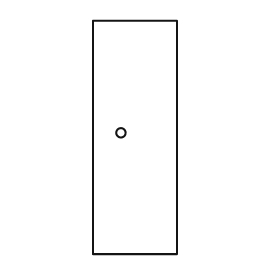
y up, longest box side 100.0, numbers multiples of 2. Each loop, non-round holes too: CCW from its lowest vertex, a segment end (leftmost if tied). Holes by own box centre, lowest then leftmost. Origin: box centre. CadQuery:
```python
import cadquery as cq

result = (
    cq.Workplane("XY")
    .moveTo(-18.0, -50.0)
    .lineTo(18.0, -50.0)
    .lineTo(18.0, 50.0)
    .lineTo(-18.0, 50.0)
    .close()
    .moveTo(-6.0, 2.0)
    .circle(2.0)
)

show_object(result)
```